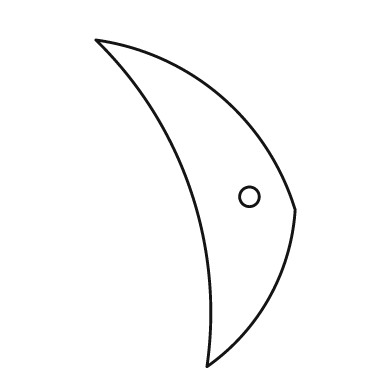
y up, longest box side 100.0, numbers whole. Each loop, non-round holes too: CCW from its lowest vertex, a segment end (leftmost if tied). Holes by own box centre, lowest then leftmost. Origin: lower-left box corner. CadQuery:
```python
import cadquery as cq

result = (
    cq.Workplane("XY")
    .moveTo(34.0, 0.0)
    .threePointArc((53.0, 21.0), (61.0, 48.0))
    .threePointArc((38.0, 83.0), (0.0, 100.0))
    .threePointArc((29.0, 54.0), (34.0, 0.0))
    .close()
    .moveTo(47.0, 52.0)
    .circle(3.0)
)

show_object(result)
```